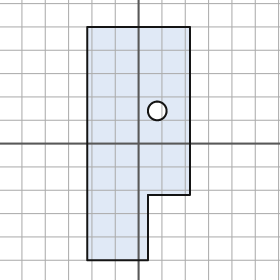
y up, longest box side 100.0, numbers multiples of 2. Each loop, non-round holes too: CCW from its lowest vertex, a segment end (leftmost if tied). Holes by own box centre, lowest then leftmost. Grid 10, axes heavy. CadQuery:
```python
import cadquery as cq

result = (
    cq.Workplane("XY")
    .moveTo(-22.0, -50.0)
    .lineTo(4.0, -50.0)
    .lineTo(4.0, -22.0)
    .lineTo(22.0, -22.0)
    .lineTo(22.0, 50.0)
    .lineTo(-22.0, 50.0)
    .close()
    .moveTo(8.0, 14.0)
    .circle(4.0)
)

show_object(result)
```